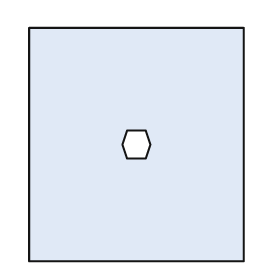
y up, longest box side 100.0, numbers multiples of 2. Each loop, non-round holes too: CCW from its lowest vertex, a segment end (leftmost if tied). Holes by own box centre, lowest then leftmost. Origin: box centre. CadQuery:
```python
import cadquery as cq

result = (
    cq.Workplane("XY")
    .moveTo(-46.0, -50.0)
    .lineTo(46.0, -50.0)
    .lineTo(46.0, 50.0)
    .lineTo(-46.0, 50.0)
    .close()
    .moveTo(-4.0, -6.0)
    .lineTo(4.0, -6.0)
    .lineTo(6.0, 0.0)
    .lineTo(4.0, 6.0)
    .lineTo(-4.0, 6.0)
    .lineTo(-6.0, 0.0)
    .close()
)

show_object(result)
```